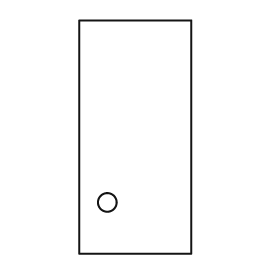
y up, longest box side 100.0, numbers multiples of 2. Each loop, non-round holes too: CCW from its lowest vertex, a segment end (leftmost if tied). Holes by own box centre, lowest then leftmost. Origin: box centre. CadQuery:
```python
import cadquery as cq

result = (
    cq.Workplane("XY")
    .moveTo(-24.0, -50.0)
    .lineTo(24.0, -50.0)
    .lineTo(24.0, 50.0)
    .lineTo(-24.0, 50.0)
    .close()
    .moveTo(-12.0, -28.0)
    .circle(4.0)
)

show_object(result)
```